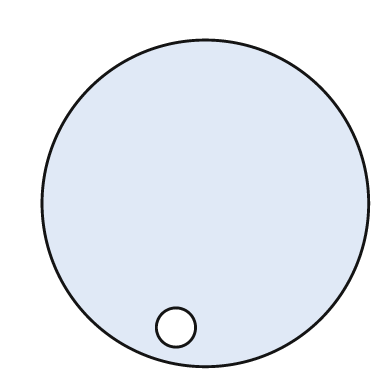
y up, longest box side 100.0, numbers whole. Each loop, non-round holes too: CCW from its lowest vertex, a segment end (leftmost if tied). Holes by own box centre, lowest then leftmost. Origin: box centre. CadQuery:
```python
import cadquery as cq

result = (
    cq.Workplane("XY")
    .moveTo(0.0, 0.0)
    .circle(50.0)
    .moveTo(-9.0, -38.0)
    .circle(6.0)
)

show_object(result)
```